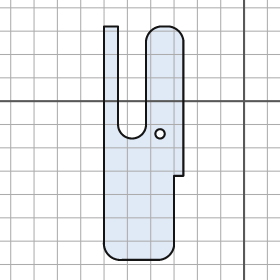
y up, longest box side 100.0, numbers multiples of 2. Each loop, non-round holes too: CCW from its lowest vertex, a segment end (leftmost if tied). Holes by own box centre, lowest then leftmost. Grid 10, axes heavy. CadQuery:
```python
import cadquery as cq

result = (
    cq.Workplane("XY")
    .moveTo(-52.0, -68.0)
    .lineTo(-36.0, -68.0)
    .threePointArc((-32.0, -66.0), (-30.0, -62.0))
    .lineTo(-30.0, -32.0)
    .lineTo(-26.0, -32.0)
    .lineTo(-26.0, 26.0)
    .threePointArc((-28.0, 30.0), (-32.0, 32.0))
    .lineTo(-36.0, 32.0)
    .threePointArc((-40.0, 30.0), (-42.0, 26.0))
    .lineTo(-42.0, -10.0)
    .threePointArc((-48.0, -16.0), (-54.0, -10.0))
    .lineTo(-54.0, 32.0)
    .lineTo(-60.0, 32.0)
    .lineTo(-60.0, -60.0)
    .threePointArc((-58.0, -66.0), (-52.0, -68.0))
    .close()
    .moveTo(-36.0, -14.0)
    .circle(2.0)
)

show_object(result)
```